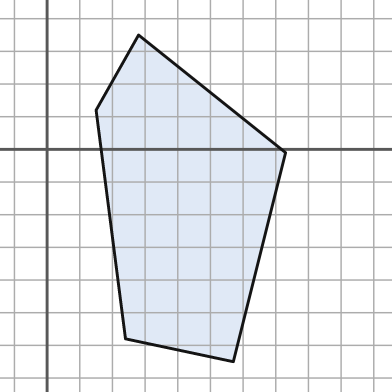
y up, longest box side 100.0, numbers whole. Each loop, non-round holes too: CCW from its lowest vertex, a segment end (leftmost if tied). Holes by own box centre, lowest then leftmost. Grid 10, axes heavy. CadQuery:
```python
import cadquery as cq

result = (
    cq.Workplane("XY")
    .moveTo(57.0, -65.0)
    .lineTo(73.0, -1.0)
    .lineTo(28.0, 35.0)
    .lineTo(15.0, 12.0)
    .lineTo(24.0, -58.0)
    .close()
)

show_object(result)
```